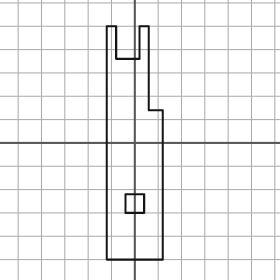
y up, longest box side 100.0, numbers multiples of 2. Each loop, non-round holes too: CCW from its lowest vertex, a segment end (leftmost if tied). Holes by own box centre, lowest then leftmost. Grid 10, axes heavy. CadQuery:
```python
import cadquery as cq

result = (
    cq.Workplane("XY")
    .moveTo(-12.0, -50.0)
    .lineTo(12.0, -50.0)
    .lineTo(12.0, 14.0)
    .lineTo(6.0, 14.0)
    .lineTo(6.0, 50.0)
    .lineTo(2.0, 50.0)
    .lineTo(2.0, 36.0)
    .lineTo(-8.0, 36.0)
    .lineTo(-8.0, 50.0)
    .lineTo(-12.0, 50.0)
    .close()
    .moveTo(-4.0, -30.0)
    .lineTo(4.0, -30.0)
    .lineTo(4.0, -22.0)
    .lineTo(-4.0, -22.0)
    .close()
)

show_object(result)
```